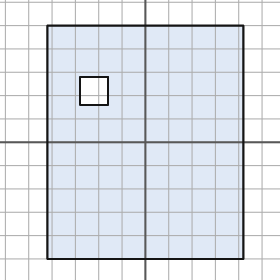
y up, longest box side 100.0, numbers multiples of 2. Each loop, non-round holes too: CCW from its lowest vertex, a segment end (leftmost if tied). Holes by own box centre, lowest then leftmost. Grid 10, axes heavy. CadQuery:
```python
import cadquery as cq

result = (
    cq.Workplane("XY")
    .moveTo(-42.0, -50.0)
    .lineTo(42.0, -50.0)
    .lineTo(42.0, 50.0)
    .lineTo(-42.0, 50.0)
    .close()
    .moveTo(-28.0, 16.0)
    .lineTo(-16.0, 16.0)
    .lineTo(-16.0, 28.0)
    .lineTo(-28.0, 28.0)
    .close()
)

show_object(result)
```